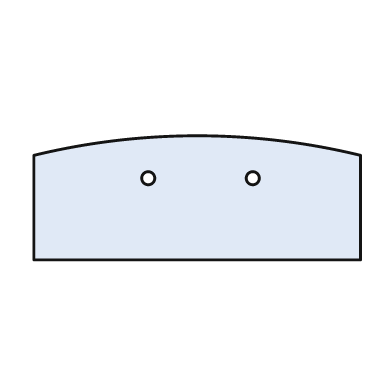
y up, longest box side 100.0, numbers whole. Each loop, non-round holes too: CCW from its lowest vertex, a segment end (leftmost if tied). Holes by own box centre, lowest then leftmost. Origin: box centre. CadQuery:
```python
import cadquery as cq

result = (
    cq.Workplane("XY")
    .moveTo(-50.0, -19.0)
    .lineTo(50.0, -19.0)
    .lineTo(50.0, 13.0)
    .threePointArc((0.0, 19.0), (-50.0, 13.0))
    .close()
    .moveTo(-15.0, 6.0)
    .circle(2.0)
    .moveTo(17.0, 6.0)
    .circle(2.0)
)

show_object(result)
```